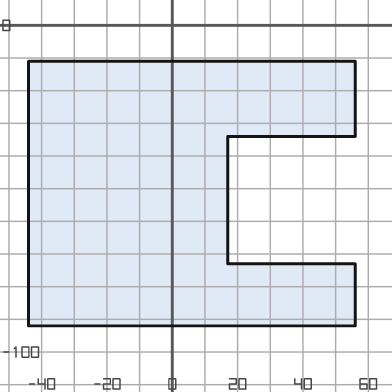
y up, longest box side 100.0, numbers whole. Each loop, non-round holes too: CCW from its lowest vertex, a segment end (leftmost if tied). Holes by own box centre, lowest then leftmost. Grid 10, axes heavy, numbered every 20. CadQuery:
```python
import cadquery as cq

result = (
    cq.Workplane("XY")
    .moveTo(-44.0, -92.0)
    .lineTo(56.0, -92.0)
    .lineTo(56.0, -73.0)
    .lineTo(17.0, -73.0)
    .lineTo(17.0, -34.0)
    .lineTo(56.0, -34.0)
    .lineTo(56.0, -11.0)
    .lineTo(-44.0, -11.0)
    .close()
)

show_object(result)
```